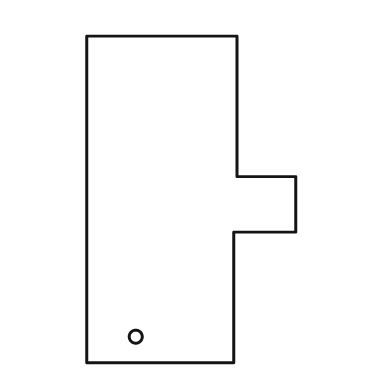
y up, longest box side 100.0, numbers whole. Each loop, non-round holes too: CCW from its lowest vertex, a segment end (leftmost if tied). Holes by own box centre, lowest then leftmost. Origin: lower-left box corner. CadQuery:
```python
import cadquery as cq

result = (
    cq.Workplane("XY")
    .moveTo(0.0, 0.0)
    .lineTo(45.0, 0.0)
    .lineTo(45.0, 40.0)
    .lineTo(64.0, 40.0)
    .lineTo(64.0, 57.0)
    .lineTo(46.0, 57.0)
    .lineTo(46.0, 100.0)
    .lineTo(0.0, 100.0)
    .close()
    .moveTo(15.0, 8.0)
    .circle(2.0)
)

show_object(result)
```